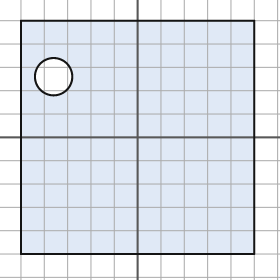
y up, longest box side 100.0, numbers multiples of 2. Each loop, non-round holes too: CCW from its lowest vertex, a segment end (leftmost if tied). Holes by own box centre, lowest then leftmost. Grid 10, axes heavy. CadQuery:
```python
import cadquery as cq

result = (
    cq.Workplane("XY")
    .moveTo(-50.0, -50.0)
    .lineTo(50.0, -50.0)
    .lineTo(50.0, 50.0)
    .lineTo(-50.0, 50.0)
    .close()
    .moveTo(-36.0, 26.0)
    .circle(8.0)
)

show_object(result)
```